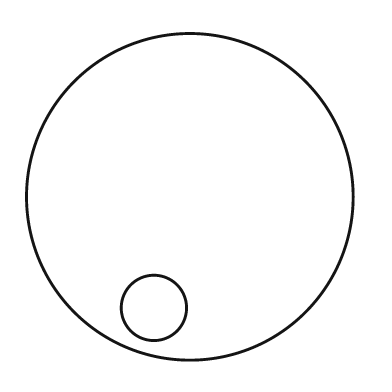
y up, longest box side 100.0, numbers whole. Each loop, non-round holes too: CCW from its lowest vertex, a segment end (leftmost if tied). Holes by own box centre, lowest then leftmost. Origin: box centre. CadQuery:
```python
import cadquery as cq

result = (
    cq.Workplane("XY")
    .moveTo(0.0, 0.0)
    .circle(50.0)
    .moveTo(-11.0, -34.0)
    .circle(10.0)
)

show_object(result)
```